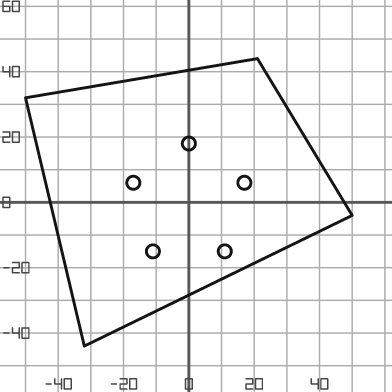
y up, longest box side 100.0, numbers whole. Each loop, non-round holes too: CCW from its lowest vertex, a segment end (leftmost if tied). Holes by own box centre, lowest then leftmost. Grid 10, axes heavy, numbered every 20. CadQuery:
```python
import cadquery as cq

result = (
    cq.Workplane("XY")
    .moveTo(-32.0, -44.0)
    .lineTo(50.0, -4.0)
    .lineTo(21.0, 44.0)
    .lineTo(-50.0, 32.0)
    .close()
    .moveTo(-11.0, -15.0)
    .circle(2.0)
    .moveTo(11.0, -15.0)
    .circle(2.0)
    .moveTo(-17.0, 6.0)
    .circle(2.0)
    .moveTo(17.0, 6.0)
    .circle(2.0)
    .moveTo(0.0, 18.0)
    .circle(2.0)
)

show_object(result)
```